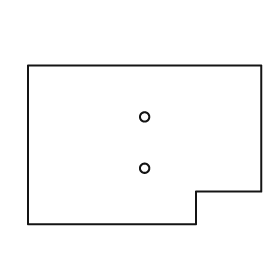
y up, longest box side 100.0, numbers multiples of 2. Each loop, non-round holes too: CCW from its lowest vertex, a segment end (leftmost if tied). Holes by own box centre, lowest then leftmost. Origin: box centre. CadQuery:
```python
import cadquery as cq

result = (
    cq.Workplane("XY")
    .moveTo(-50.0, -34.0)
    .lineTo(22.0, -34.0)
    .lineTo(22.0, -20.0)
    .lineTo(50.0, -20.0)
    .lineTo(50.0, 34.0)
    .lineTo(-50.0, 34.0)
    .close()
    .moveTo(0.0, -10.0)
    .circle(2.0)
    .moveTo(0.0, 12.0)
    .circle(2.0)
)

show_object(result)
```